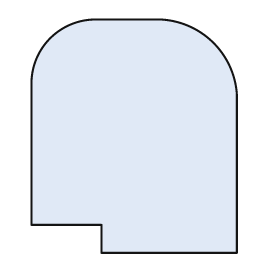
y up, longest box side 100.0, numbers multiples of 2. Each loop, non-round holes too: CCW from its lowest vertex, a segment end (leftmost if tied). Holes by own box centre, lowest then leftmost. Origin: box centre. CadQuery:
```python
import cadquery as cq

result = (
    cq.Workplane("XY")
    .moveTo(-14.0, -50.0)
    .lineTo(44.0, -50.0)
    .lineTo(44.0, 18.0)
    .threePointArc((34.0, 40.0), (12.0, 50.0))
    .lineTo(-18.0, 50.0)
    .threePointArc((-36.0, 42.0), (-44.0, 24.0))
    .lineTo(-44.0, -38.0)
    .lineTo(-14.0, -38.0)
    .close()
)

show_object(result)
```